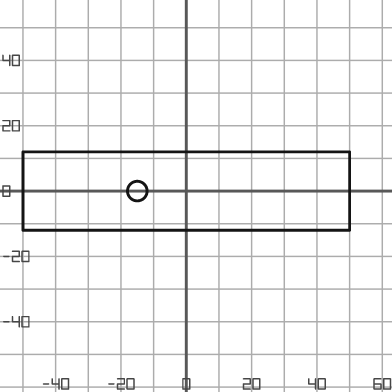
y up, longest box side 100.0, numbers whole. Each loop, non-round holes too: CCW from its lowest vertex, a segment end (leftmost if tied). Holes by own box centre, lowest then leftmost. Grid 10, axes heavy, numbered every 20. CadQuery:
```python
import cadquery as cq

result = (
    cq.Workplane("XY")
    .moveTo(-50.0, -12.0)
    .lineTo(50.0, -12.0)
    .lineTo(50.0, 12.0)
    .lineTo(-50.0, 12.0)
    .close()
    .moveTo(-15.0, 0.0)
    .circle(3.0)
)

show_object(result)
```